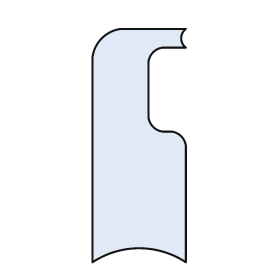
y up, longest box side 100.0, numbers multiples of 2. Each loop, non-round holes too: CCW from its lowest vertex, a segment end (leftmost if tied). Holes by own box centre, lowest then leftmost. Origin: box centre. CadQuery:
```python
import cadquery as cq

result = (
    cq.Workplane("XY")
    .moveTo(-20.0, -50.0)
    .threePointArc((0.0, -44.0), (20.0, -50.0))
    .lineTo(20.0, 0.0)
    .threePointArc((18.0, 4.0), (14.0, 6.0))
    .lineTo(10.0, 6.0)
    .threePointArc((6.0, 8.0), (4.0, 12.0))
    .lineTo(4.0, 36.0)
    .threePointArc((6.0, 40.0), (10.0, 42.0))
    .lineTo(20.0, 42.0)
    .threePointArc((18.0, 46.0), (20.0, 50.0))
    .lineTo(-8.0, 50.0)
    .threePointArc((-16.0, 46.0), (-20.0, 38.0))
    .close()
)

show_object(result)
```